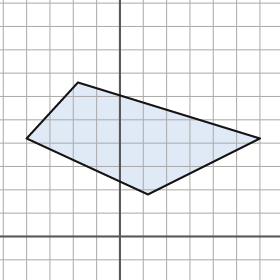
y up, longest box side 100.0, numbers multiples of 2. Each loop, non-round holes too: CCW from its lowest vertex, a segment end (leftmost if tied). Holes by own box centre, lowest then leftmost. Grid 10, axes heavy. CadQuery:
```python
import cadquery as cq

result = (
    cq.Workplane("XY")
    .moveTo(12.0, 18.0)
    .lineTo(60.0, 42.0)
    .lineTo(-18.0, 66.0)
    .lineTo(-40.0, 42.0)
    .close()
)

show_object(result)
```